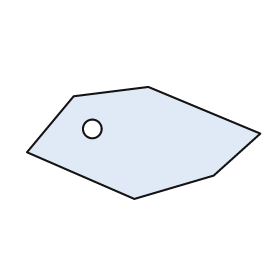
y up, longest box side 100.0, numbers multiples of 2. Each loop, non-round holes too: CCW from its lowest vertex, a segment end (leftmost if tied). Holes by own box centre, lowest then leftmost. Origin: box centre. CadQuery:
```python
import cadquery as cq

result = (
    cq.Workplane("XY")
    .moveTo(-4.0, -24.0)
    .lineTo(30.0, -14.0)
    .lineTo(50.0, 4.0)
    .lineTo(2.0, 24.0)
    .lineTo(-30.0, 20.0)
    .lineTo(-50.0, -4.0)
    .close()
    .moveTo(-22.0, 6.0)
    .circle(4.0)
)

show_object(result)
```